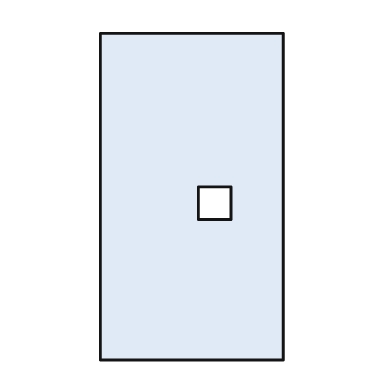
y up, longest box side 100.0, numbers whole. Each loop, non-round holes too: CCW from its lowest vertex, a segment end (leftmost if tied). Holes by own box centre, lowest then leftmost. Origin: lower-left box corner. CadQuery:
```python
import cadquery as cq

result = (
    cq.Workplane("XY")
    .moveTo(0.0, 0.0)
    .lineTo(56.0, 0.0)
    .lineTo(56.0, 100.0)
    .lineTo(0.0, 100.0)
    .close()
    .moveTo(30.0, 43.0)
    .lineTo(40.0, 43.0)
    .lineTo(40.0, 53.0)
    .lineTo(30.0, 53.0)
    .close()
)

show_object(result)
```